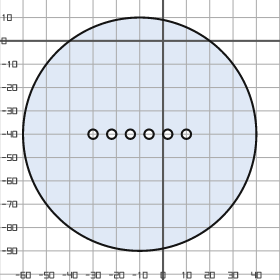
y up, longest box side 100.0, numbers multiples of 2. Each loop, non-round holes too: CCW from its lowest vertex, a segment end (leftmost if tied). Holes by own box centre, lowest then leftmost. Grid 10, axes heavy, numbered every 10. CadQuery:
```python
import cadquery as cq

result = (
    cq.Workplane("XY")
    .moveTo(-10.0, -40.0)
    .circle(50.0)
    .moveTo(-30.0, -40.0)
    .circle(2.0)
    .moveTo(-22.0, -40.0)
    .circle(2.0)
    .moveTo(-14.0, -40.0)
    .circle(2.0)
    .moveTo(-6.0, -40.0)
    .circle(2.0)
    .moveTo(2.0, -40.0)
    .circle(2.0)
    .moveTo(10.0, -40.0)
    .circle(2.0)
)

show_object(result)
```